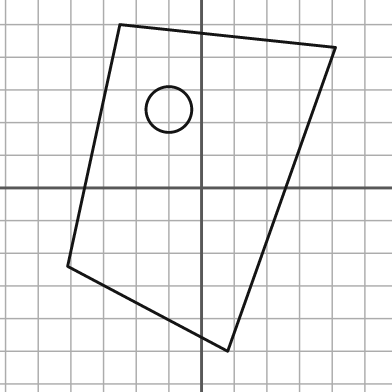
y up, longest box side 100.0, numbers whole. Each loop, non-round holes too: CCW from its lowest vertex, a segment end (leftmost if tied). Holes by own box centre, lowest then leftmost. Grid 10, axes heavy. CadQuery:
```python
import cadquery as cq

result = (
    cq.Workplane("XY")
    .moveTo(8.0, -50.0)
    .lineTo(41.0, 43.0)
    .lineTo(-25.0, 50.0)
    .lineTo(-41.0, -24.0)
    .close()
    .moveTo(-10.0, 24.0)
    .circle(7.0)
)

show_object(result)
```